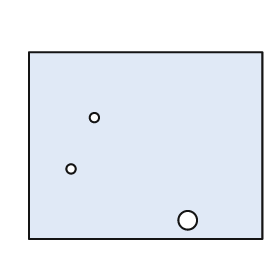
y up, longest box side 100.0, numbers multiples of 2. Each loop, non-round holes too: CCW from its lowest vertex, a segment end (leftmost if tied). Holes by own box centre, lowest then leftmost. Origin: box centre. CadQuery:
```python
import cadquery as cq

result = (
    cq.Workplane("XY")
    .moveTo(-50.0, -40.0)
    .lineTo(50.0, -40.0)
    .lineTo(50.0, 40.0)
    .lineTo(-50.0, 40.0)
    .close()
    .moveTo(18.0, -32.0)
    .circle(4.0)
    .moveTo(-32.0, -10.0)
    .circle(2.0)
    .moveTo(-22.0, 12.0)
    .circle(2.0)
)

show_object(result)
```